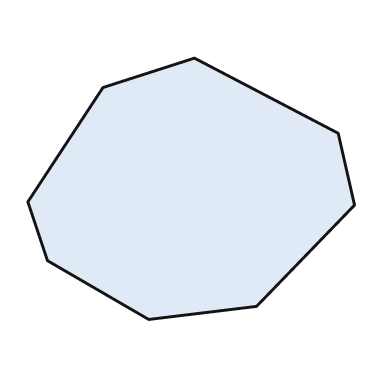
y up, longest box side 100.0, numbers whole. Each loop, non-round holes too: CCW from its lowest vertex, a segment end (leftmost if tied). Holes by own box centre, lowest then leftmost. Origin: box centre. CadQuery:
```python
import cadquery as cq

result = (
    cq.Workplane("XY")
    .moveTo(-13.0, -40.0)
    .lineTo(20.0, -36.0)
    .lineTo(50.0, -5.0)
    .lineTo(45.0, 17.0)
    .lineTo(1.0, 40.0)
    .lineTo(-27.0, 31.0)
    .lineTo(-50.0, -4.0)
    .lineTo(-44.0, -22.0)
    .close()
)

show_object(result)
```